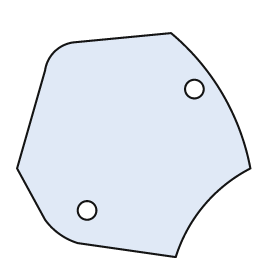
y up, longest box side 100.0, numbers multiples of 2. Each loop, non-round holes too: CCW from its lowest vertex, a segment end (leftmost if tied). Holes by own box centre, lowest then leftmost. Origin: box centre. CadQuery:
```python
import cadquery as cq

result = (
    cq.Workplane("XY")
    .moveTo(18.0, -48.0)
    .threePointArc((30.0, -26.0), (50.0, -10.0))
    .threePointArc((38.0, 22.0), (16.0, 48.0))
    .lineTo(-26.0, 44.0)
    .threePointArc((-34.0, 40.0), (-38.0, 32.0))
    .lineTo(-50.0, -10.0)
    .lineTo(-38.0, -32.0)
    .threePointArc((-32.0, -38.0), (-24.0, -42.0))
    .close()
    .moveTo(-20.0, -28.0)
    .circle(4.0)
    .moveTo(26.0, 24.0)
    .circle(4.0)
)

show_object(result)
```